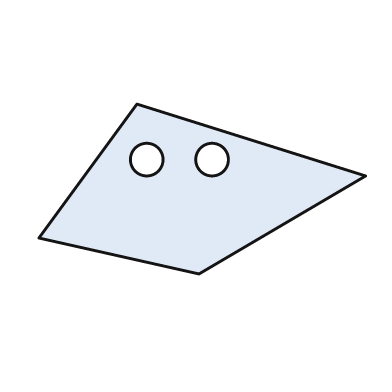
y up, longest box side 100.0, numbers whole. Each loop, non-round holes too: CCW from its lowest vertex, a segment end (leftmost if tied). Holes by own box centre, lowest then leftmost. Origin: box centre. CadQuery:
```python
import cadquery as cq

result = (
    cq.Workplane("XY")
    .moveTo(-1.0, -26.0)
    .lineTo(50.0, 4.0)
    .lineTo(-20.0, 26.0)
    .lineTo(-50.0, -15.0)
    .close()
    .moveTo(-17.0, 9.0)
    .circle(5.0)
    .moveTo(3.0, 9.0)
    .circle(5.0)
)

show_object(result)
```